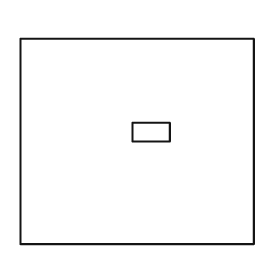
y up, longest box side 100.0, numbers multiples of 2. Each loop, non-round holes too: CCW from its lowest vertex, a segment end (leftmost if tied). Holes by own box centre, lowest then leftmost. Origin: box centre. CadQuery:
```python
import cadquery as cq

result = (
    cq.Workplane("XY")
    .moveTo(-50.0, -44.0)
    .lineTo(50.0, -44.0)
    .lineTo(50.0, 44.0)
    .lineTo(-50.0, 44.0)
    .close()
    .moveTo(-2.0, 0.0)
    .lineTo(14.0, 0.0)
    .lineTo(14.0, 8.0)
    .lineTo(-2.0, 8.0)
    .close()
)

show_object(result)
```